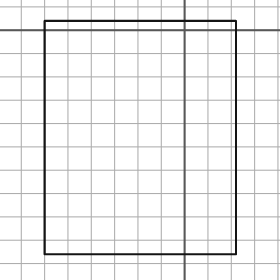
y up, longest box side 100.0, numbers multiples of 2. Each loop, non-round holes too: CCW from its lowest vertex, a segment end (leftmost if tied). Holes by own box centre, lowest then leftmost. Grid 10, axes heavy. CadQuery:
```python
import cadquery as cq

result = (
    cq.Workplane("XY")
    .moveTo(-60.0, -96.0)
    .lineTo(22.0, -96.0)
    .lineTo(22.0, 4.0)
    .lineTo(-60.0, 4.0)
    .close()
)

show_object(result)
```